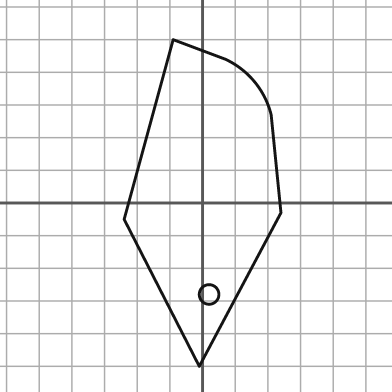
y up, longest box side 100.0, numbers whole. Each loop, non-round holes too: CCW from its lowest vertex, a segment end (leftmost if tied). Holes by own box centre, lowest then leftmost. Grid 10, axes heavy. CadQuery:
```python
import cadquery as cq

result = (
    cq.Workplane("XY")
    .moveTo(-1.0, -50.0)
    .lineTo(24.0, -3.0)
    .lineTo(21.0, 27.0)
    .threePointArc((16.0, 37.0), (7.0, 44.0))
    .lineTo(-9.0, 50.0)
    .lineTo(-24.0, -5.0)
    .close()
    .moveTo(2.0, -28.0)
    .circle(3.0)
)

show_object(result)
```